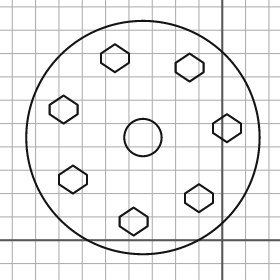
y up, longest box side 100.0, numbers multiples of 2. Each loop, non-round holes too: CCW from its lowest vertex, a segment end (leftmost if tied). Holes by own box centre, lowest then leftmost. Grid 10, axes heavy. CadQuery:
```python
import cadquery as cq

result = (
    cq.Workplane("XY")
    .moveTo(-34.0, 44.0)
    .circle(50.0)
    .moveTo(-38.0, 2.0)
    .lineTo(-32.0, 6.0)
    .lineTo(-32.0, 10.0)
    .lineTo(-38.0, 14.0)
    .lineTo(-44.0, 10.0)
    .lineTo(-44.0, 6.0)
    .close()
    .moveTo(-10.0, 12.0)
    .lineTo(-4.0, 16.0)
    .lineTo(-4.0, 20.0)
    .lineTo(-10.0, 24.0)
    .lineTo(-16.0, 20.0)
    .lineTo(-16.0, 16.0)
    .close()
    .moveTo(-64.0, 20.0)
    .lineTo(-58.0, 24.0)
    .lineTo(-58.0, 28.0)
    .lineTo(-64.0, 32.0)
    .lineTo(-70.0, 28.0)
    .lineTo(-70.0, 24.0)
    .close()
    .moveTo(-34.0, 44.0)
    .circle(8.0)
    .moveTo(2.0, 42.0)
    .lineTo(8.0, 46.0)
    .lineTo(8.0, 50.0)
    .lineTo(2.0, 54.0)
    .lineTo(-4.0, 50.0)
    .lineTo(-4.0, 46.0)
    .close()
    .moveTo(-68.0, 50.0)
    .lineTo(-62.0, 54.0)
    .lineTo(-62.0, 58.0)
    .lineTo(-68.0, 62.0)
    .lineTo(-74.0, 58.0)
    .lineTo(-74.0, 54.0)
    .close()
    .moveTo(-14.0, 68.0)
    .lineTo(-8.0, 72.0)
    .lineTo(-8.0, 76.0)
    .lineTo(-14.0, 80.0)
    .lineTo(-20.0, 76.0)
    .lineTo(-20.0, 72.0)
    .close()
    .moveTo(-46.0, 72.0)
    .lineTo(-40.0, 76.0)
    .lineTo(-40.0, 80.0)
    .lineTo(-46.0, 84.0)
    .lineTo(-52.0, 80.0)
    .lineTo(-52.0, 76.0)
    .close()
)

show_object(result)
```